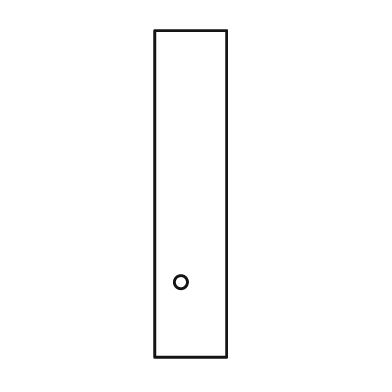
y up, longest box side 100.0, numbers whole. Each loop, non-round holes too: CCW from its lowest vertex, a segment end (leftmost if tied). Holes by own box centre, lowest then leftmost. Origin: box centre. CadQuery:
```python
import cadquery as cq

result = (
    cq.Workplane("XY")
    .moveTo(-11.0, -50.0)
    .lineTo(11.0, -50.0)
    .lineTo(11.0, 50.0)
    .lineTo(-11.0, 50.0)
    .close()
    .moveTo(-3.0, -27.0)
    .circle(2.0)
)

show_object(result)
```